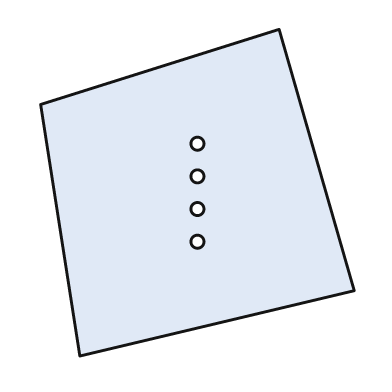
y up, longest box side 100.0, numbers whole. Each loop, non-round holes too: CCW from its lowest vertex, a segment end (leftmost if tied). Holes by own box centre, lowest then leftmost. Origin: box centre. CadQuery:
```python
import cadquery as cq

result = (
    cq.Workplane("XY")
    .moveTo(-36.0, -50.0)
    .lineTo(48.0, -30.0)
    .lineTo(25.0, 50.0)
    .lineTo(-48.0, 27.0)
    .close()
    .moveTo(0.0, -15.0)
    .circle(2.0)
    .moveTo(0.0, -5.0)
    .circle(2.0)
    .moveTo(0.0, 5.0)
    .circle(2.0)
    .moveTo(0.0, 15.0)
    .circle(2.0)
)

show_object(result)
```